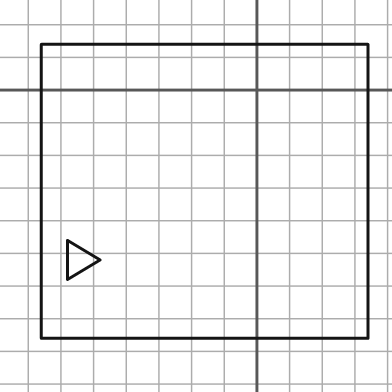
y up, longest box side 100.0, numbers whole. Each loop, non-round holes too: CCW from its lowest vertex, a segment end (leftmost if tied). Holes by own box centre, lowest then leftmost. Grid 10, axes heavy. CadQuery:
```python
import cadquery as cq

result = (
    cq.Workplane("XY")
    .moveTo(-66.0, -76.0)
    .lineTo(34.0, -76.0)
    .lineTo(34.0, 14.0)
    .lineTo(-66.0, 14.0)
    .close()
    .moveTo(-58.0, -58.0)
    .lineTo(-48.0, -52.0)
    .lineTo(-58.0, -46.0)
    .close()
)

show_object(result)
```